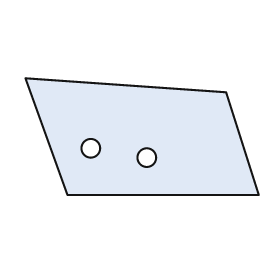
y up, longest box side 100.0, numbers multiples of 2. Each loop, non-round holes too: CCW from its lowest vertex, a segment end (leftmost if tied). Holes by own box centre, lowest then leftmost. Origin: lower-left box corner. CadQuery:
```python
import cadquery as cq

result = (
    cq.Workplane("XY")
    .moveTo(18.0, 0.0)
    .lineTo(100.0, 0.0)
    .lineTo(86.0, 44.0)
    .lineTo(0.0, 50.0)
    .close()
    .moveTo(52.0, 16.0)
    .circle(4.0)
    .moveTo(28.0, 20.0)
    .circle(4.0)
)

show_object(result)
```